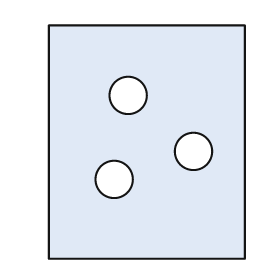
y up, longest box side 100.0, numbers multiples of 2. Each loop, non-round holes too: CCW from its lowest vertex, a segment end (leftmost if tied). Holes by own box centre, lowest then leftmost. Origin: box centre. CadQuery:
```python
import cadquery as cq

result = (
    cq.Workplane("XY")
    .moveTo(-42.0, -50.0)
    .lineTo(42.0, -50.0)
    .lineTo(42.0, 50.0)
    .lineTo(-42.0, 50.0)
    .close()
    .moveTo(-14.0, -16.0)
    .circle(8.0)
    .moveTo(20.0, -4.0)
    .circle(8.0)
    .moveTo(-8.0, 20.0)
    .circle(8.0)
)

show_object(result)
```